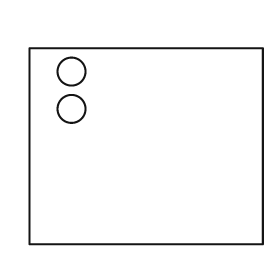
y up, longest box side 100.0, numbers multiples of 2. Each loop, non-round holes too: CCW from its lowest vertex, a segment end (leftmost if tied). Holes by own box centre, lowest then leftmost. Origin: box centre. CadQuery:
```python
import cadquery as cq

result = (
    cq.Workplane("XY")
    .moveTo(-50.0, -42.0)
    .lineTo(50.0, -42.0)
    .lineTo(50.0, 42.0)
    .lineTo(-50.0, 42.0)
    .close()
    .moveTo(-32.0, 16.0)
    .circle(6.0)
    .moveTo(-32.0, 32.0)
    .circle(6.0)
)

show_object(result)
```